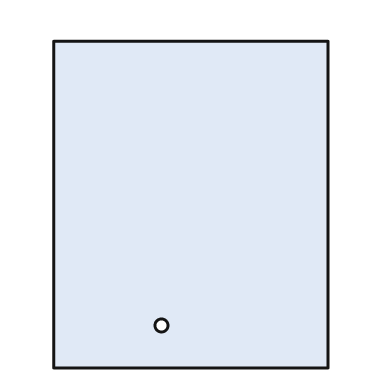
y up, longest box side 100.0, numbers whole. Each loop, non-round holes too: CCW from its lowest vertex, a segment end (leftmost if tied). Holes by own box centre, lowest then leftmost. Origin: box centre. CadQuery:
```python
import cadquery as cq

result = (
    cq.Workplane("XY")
    .moveTo(-42.0, -50.0)
    .lineTo(42.0, -50.0)
    .lineTo(42.0, 50.0)
    .lineTo(-42.0, 50.0)
    .close()
    .moveTo(-9.0, -37.0)
    .circle(2.0)
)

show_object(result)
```